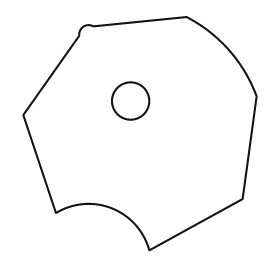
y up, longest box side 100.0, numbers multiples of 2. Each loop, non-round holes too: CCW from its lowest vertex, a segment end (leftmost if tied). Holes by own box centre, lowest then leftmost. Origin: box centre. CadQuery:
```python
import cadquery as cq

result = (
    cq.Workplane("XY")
    .moveTo(4.0, -50.0)
    .lineTo(44.0, -28.0)
    .lineTo(50.0, 16.0)
    .threePointArc((38.0, 36.0), (20.0, 50.0))
    .lineTo(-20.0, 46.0)
    .threePointArc((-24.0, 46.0), (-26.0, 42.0))
    .lineTo(-50.0, 8.0)
    .lineTo(-36.0, -34.0)
    .threePointArc((-12.0, -32.0), (4.0, -50.0))
    .close()
    .moveTo(-4.0, 14.0)
    .circle(8.0)
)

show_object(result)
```